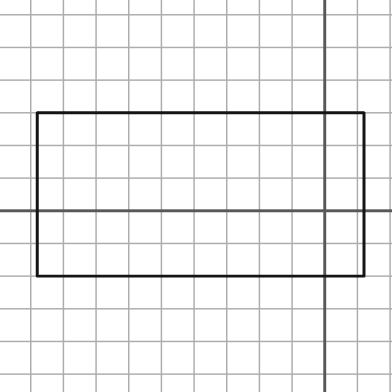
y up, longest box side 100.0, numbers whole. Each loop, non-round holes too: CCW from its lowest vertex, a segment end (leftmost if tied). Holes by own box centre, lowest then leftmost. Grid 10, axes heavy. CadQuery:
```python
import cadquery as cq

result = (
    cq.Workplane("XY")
    .moveTo(-88.0, -20.0)
    .lineTo(12.0, -20.0)
    .lineTo(12.0, 30.0)
    .lineTo(-88.0, 30.0)
    .close()
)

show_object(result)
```